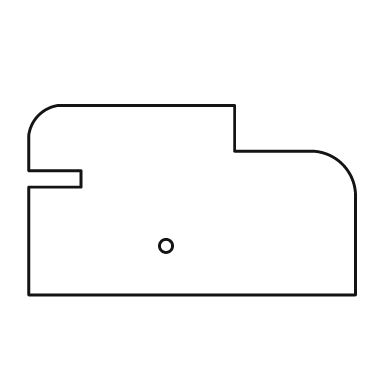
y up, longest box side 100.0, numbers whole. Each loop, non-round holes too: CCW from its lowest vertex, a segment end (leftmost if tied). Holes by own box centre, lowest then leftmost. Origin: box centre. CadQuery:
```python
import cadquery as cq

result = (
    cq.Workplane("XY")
    .moveTo(-50.0, -29.0)
    .lineTo(50.0, -29.0)
    .lineTo(50.0, 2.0)
    .threePointArc((46.0, 11.0), (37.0, 15.0))
    .lineTo(13.0, 15.0)
    .lineTo(13.0, 29.0)
    .lineTo(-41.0, 29.0)
    .threePointArc((-47.0, 26.0), (-50.0, 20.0))
    .lineTo(-50.0, 9.0)
    .lineTo(-34.0, 9.0)
    .lineTo(-34.0, 4.0)
    .lineTo(-50.0, 4.0)
    .close()
    .moveTo(-8.0, -14.0)
    .circle(2.0)
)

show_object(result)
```